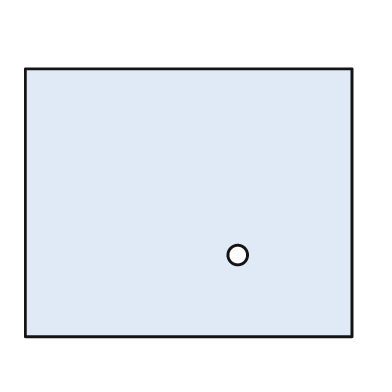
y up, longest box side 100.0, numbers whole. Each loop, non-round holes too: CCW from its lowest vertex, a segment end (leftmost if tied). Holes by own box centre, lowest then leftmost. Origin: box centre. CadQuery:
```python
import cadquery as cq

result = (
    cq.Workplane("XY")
    .moveTo(-50.0, -41.0)
    .lineTo(50.0, -41.0)
    .lineTo(50.0, 41.0)
    .lineTo(-50.0, 41.0)
    .close()
    .moveTo(15.0, -16.0)
    .circle(3.0)
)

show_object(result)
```